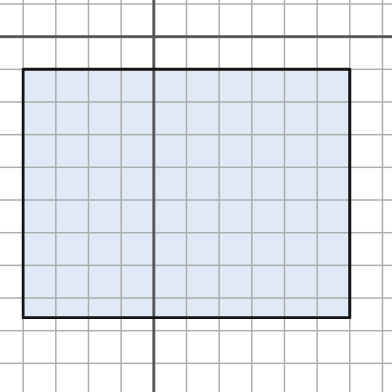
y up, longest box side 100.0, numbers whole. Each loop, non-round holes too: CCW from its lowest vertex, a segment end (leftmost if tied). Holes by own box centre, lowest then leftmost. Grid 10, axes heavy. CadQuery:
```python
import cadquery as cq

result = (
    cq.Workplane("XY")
    .moveTo(-40.0, -86.0)
    .lineTo(60.0, -86.0)
    .lineTo(60.0, -10.0)
    .lineTo(-40.0, -10.0)
    .close()
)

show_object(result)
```